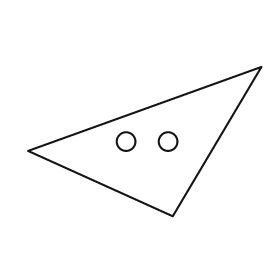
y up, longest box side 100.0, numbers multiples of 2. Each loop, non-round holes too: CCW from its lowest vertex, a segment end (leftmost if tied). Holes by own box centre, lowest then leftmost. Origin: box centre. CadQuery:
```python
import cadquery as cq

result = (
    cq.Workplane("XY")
    .moveTo(12.0, -32.0)
    .lineTo(50.0, 32.0)
    .lineTo(-50.0, -4.0)
    .close()
    .moveTo(-8.0, 0.0)
    .circle(4.0)
    .moveTo(10.0, 0.0)
    .circle(4.0)
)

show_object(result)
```